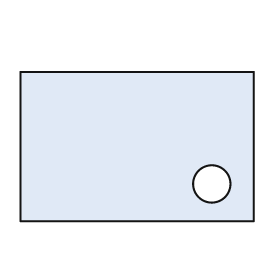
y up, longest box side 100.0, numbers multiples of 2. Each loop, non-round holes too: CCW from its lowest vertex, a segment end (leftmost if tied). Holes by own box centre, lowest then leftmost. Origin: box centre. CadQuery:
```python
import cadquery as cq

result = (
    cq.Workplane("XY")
    .moveTo(-50.0, -32.0)
    .lineTo(50.0, -32.0)
    .lineTo(50.0, 32.0)
    .lineTo(-50.0, 32.0)
    .close()
    .moveTo(32.0, -16.0)
    .circle(8.0)
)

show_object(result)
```